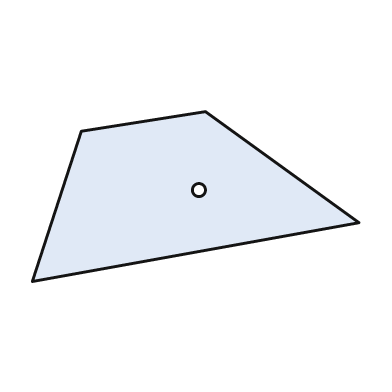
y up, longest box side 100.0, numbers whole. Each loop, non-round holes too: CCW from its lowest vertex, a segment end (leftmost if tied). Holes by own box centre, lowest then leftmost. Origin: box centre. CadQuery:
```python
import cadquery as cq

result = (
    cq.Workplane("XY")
    .moveTo(-50.0, -26.0)
    .lineTo(50.0, -8.0)
    .lineTo(3.0, 26.0)
    .lineTo(-35.0, 20.0)
    .close()
    .moveTo(1.0, 2.0)
    .circle(2.0)
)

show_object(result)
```